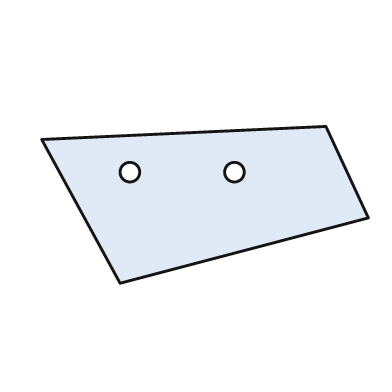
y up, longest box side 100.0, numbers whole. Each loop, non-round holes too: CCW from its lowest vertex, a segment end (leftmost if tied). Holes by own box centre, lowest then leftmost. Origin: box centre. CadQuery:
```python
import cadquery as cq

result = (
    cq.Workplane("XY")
    .moveTo(-26.0, -24.0)
    .lineTo(50.0, -4.0)
    .lineTo(37.0, 24.0)
    .lineTo(-50.0, 20.0)
    .close()
    .moveTo(-23.0, 10.0)
    .circle(3.0)
    .moveTo(9.0, 10.0)
    .circle(3.0)
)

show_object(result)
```